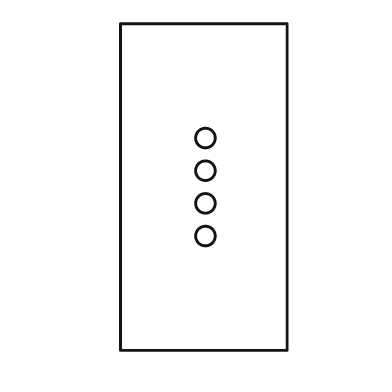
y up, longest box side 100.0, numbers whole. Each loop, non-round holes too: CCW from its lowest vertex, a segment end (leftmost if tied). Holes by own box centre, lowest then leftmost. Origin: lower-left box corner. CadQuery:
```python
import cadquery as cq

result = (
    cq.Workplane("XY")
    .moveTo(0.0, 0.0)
    .lineTo(51.0, 0.0)
    .lineTo(51.0, 100.0)
    .lineTo(0.0, 100.0)
    .close()
    .moveTo(26.0, 35.0)
    .circle(3.0)
    .moveTo(26.0, 45.0)
    .circle(3.0)
    .moveTo(26.0, 55.0)
    .circle(3.0)
    .moveTo(26.0, 65.0)
    .circle(3.0)
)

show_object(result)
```